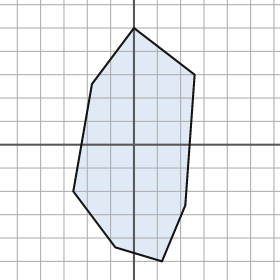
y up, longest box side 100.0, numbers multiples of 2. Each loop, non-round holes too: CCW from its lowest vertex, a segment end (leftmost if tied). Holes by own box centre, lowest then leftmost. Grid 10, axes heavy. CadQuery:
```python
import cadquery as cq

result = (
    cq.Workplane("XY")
    .moveTo(12.0, -50.0)
    .lineTo(22.0, -26.0)
    .lineTo(26.0, 30.0)
    .lineTo(0.0, 50.0)
    .lineTo(-18.0, 26.0)
    .lineTo(-26.0, -20.0)
    .lineTo(-8.0, -44.0)
    .close()
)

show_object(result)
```